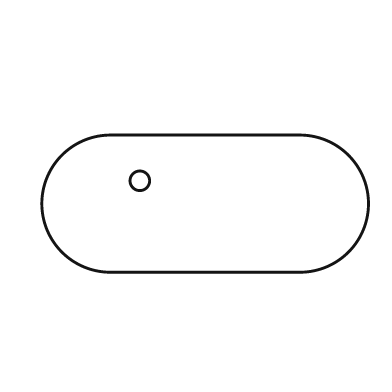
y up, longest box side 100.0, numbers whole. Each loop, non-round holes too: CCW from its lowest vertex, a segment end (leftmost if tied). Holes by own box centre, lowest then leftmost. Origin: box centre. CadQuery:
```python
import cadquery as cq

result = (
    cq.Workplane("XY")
    .moveTo(-29.0, -21.0)
    .lineTo(29.0, -21.0)
    .threePointArc((50.0, 0.0), (29.0, 21.0))
    .lineTo(-29.0, 21.0)
    .threePointArc((-50.0, 0.0), (-29.0, -21.0))
    .close()
    .moveTo(-20.0, 7.0)
    .circle(3.0)
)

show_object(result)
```